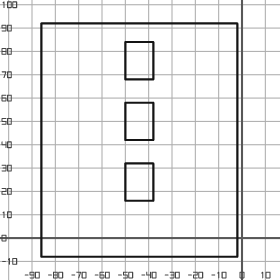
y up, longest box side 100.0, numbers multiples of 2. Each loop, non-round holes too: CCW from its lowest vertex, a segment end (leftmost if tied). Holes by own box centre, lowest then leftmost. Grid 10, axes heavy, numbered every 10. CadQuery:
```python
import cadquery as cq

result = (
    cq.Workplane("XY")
    .moveTo(-86.0, -8.0)
    .lineTo(-2.0, -8.0)
    .lineTo(-2.0, 92.0)
    .lineTo(-86.0, 92.0)
    .close()
    .moveTo(-50.0, 16.0)
    .lineTo(-38.0, 16.0)
    .lineTo(-38.0, 32.0)
    .lineTo(-50.0, 32.0)
    .close()
    .moveTo(-50.0, 42.0)
    .lineTo(-38.0, 42.0)
    .lineTo(-38.0, 58.0)
    .lineTo(-50.0, 58.0)
    .close()
    .moveTo(-50.0, 68.0)
    .lineTo(-38.0, 68.0)
    .lineTo(-38.0, 84.0)
    .lineTo(-50.0, 84.0)
    .close()
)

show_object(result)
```